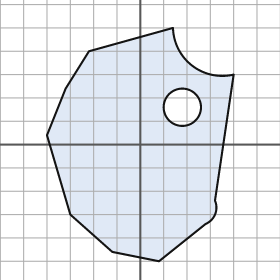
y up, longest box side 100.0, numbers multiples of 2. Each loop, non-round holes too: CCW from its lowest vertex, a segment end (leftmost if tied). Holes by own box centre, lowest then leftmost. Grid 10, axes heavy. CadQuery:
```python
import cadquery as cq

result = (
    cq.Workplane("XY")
    .moveTo(8.0, -50.0)
    .lineTo(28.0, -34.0)
    .threePointArc((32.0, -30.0), (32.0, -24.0))
    .lineTo(40.0, 30.0)
    .threePointArc((22.0, 34.0), (14.0, 50.0))
    .lineTo(-22.0, 40.0)
    .lineTo(-32.0, 24.0)
    .lineTo(-40.0, 4.0)
    .lineTo(-30.0, -30.0)
    .lineTo(-12.0, -46.0)
    .close()
    .moveTo(18.0, 16.0)
    .circle(8.0)
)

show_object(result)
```